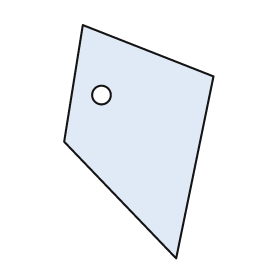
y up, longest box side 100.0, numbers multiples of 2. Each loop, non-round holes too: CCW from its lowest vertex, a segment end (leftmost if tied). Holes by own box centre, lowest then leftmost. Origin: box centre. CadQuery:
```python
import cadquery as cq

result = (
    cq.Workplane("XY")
    .moveTo(16.0, -50.0)
    .lineTo(32.0, 28.0)
    .lineTo(-24.0, 50.0)
    .lineTo(-32.0, 0.0)
    .close()
    .moveTo(-16.0, 20.0)
    .circle(4.0)
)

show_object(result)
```